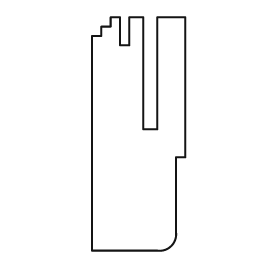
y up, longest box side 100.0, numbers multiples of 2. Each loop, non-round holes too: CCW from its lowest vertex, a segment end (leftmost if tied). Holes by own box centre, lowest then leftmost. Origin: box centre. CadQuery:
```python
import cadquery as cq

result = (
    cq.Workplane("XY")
    .moveTo(-20.0, -50.0)
    .lineTo(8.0, -50.0)
    .threePointArc((14.0, -48.0), (16.0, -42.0))
    .lineTo(16.0, -10.0)
    .lineTo(20.0, -10.0)
    .lineTo(20.0, 50.0)
    .lineTo(8.0, 50.0)
    .lineTo(8.0, 2.0)
    .lineTo(2.0, 2.0)
    .lineTo(2.0, 50.0)
    .lineTo(-4.0, 50.0)
    .lineTo(-4.0, 38.0)
    .lineTo(-8.0, 38.0)
    .lineTo(-8.0, 50.0)
    .lineTo(-12.0, 50.0)
    .lineTo(-12.0, 46.0)
    .lineTo(-16.0, 46.0)
    .lineTo(-16.0, 42.0)
    .lineTo(-20.0, 42.0)
    .close()
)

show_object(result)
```